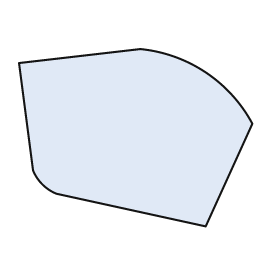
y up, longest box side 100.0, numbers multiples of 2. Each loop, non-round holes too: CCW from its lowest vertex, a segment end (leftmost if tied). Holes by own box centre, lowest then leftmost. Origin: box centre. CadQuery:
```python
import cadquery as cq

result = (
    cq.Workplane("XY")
    .moveTo(30.0, -38.0)
    .lineTo(50.0, 6.0)
    .threePointArc((30.0, 28.0), (2.0, 38.0))
    .lineTo(-50.0, 32.0)
    .lineTo(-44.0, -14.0)
    .threePointArc((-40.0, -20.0), (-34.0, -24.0))
    .close()
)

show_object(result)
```